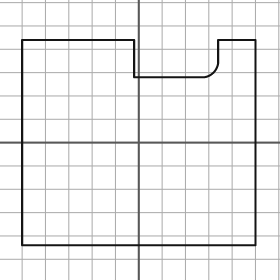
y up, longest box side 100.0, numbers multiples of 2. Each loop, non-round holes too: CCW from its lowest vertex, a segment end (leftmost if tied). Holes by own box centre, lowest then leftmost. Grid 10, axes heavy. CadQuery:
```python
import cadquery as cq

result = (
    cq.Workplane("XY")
    .moveTo(-50.0, -44.0)
    .lineTo(50.0, -44.0)
    .lineTo(50.0, 44.0)
    .lineTo(34.0, 44.0)
    .lineTo(34.0, 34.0)
    .threePointArc((32.0, 30.0), (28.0, 28.0))
    .lineTo(-2.0, 28.0)
    .lineTo(-2.0, 44.0)
    .lineTo(-50.0, 44.0)
    .close()
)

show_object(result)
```